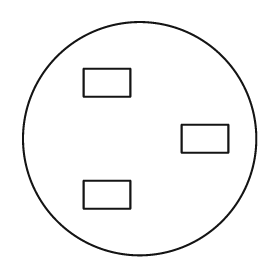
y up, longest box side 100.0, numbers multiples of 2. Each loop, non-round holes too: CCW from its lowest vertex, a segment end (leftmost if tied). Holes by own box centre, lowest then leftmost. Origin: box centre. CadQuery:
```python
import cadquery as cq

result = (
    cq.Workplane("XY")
    .moveTo(0.0, 0.0)
    .circle(50.0)
    .moveTo(-24.0, -30.0)
    .lineTo(-4.0, -30.0)
    .lineTo(-4.0, -18.0)
    .lineTo(-24.0, -18.0)
    .close()
    .moveTo(18.0, -6.0)
    .lineTo(38.0, -6.0)
    .lineTo(38.0, 6.0)
    .lineTo(18.0, 6.0)
    .close()
    .moveTo(-24.0, 18.0)
    .lineTo(-4.0, 18.0)
    .lineTo(-4.0, 30.0)
    .lineTo(-24.0, 30.0)
    .close()
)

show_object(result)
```